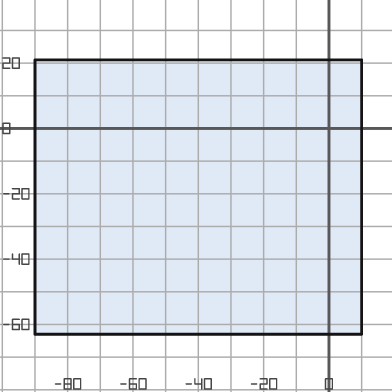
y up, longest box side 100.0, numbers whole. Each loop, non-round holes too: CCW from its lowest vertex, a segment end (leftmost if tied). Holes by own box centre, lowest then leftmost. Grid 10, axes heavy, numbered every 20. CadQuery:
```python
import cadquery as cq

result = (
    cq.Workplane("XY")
    .moveTo(-90.0, -63.0)
    .lineTo(10.0, -63.0)
    .lineTo(10.0, 21.0)
    .lineTo(-90.0, 21.0)
    .close()
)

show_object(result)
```